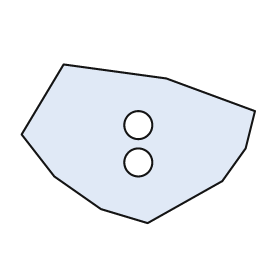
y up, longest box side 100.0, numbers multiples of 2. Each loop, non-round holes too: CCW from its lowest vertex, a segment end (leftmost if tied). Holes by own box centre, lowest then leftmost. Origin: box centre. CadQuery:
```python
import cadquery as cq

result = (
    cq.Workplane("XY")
    .moveTo(4.0, -34.0)
    .lineTo(36.0, -16.0)
    .lineTo(46.0, -2.0)
    .lineTo(50.0, 14.0)
    .lineTo(12.0, 28.0)
    .lineTo(-32.0, 34.0)
    .lineTo(-50.0, 4.0)
    .lineTo(-36.0, -14.0)
    .lineTo(-16.0, -28.0)
    .close()
    .moveTo(0.0, -8.0)
    .circle(6.0)
    .moveTo(0.0, 8.0)
    .circle(6.0)
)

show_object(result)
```